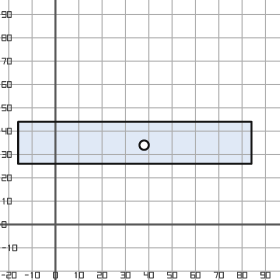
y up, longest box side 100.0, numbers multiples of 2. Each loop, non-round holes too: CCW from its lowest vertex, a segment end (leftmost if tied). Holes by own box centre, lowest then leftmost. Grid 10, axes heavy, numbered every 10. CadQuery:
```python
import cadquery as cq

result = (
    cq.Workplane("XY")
    .moveTo(-16.0, 26.0)
    .lineTo(84.0, 26.0)
    .lineTo(84.0, 44.0)
    .lineTo(-16.0, 44.0)
    .close()
    .moveTo(38.0, 34.0)
    .circle(2.0)
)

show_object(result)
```